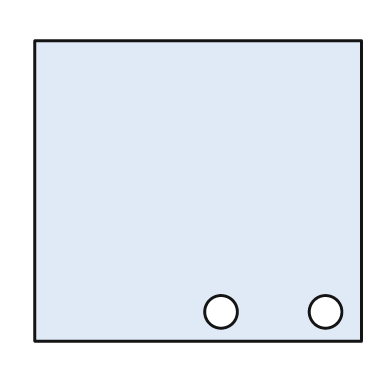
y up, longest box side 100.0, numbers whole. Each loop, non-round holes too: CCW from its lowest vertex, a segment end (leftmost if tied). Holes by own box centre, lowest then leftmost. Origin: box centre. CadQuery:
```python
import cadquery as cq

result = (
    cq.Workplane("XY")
    .moveTo(-50.0, -46.0)
    .lineTo(50.0, -46.0)
    .lineTo(50.0, 46.0)
    .lineTo(-50.0, 46.0)
    .close()
    .moveTo(7.0, -37.0)
    .circle(5.0)
    .moveTo(39.0, -37.0)
    .circle(5.0)
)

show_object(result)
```